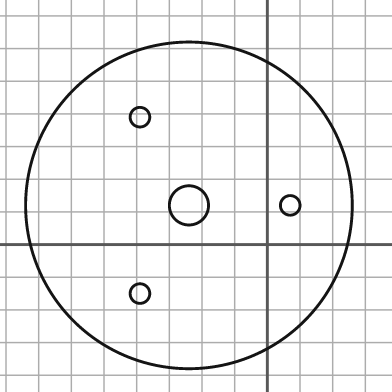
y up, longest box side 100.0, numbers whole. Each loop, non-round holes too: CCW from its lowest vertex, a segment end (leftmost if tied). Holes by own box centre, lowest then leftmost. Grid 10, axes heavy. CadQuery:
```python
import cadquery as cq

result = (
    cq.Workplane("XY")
    .moveTo(-24.0, 12.0)
    .circle(50.0)
    .moveTo(-39.0, -15.0)
    .circle(3.0)
    .moveTo(-24.0, 12.0)
    .circle(6.0)
    .moveTo(7.0, 12.0)
    .circle(3.0)
    .moveTo(-39.0, 39.0)
    .circle(3.0)
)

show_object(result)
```